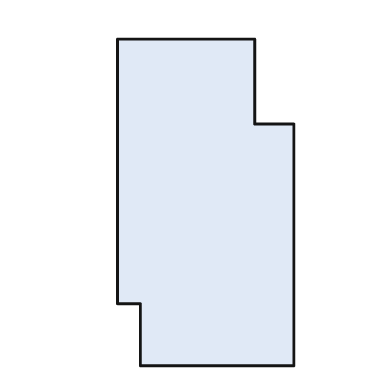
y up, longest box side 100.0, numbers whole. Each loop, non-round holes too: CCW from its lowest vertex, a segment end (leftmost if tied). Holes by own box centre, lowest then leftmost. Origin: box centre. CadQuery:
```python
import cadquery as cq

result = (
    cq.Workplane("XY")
    .moveTo(-20.0, -50.0)
    .lineTo(27.0, -50.0)
    .lineTo(27.0, 24.0)
    .lineTo(15.0, 24.0)
    .lineTo(15.0, 50.0)
    .lineTo(-27.0, 50.0)
    .lineTo(-27.0, -31.0)
    .lineTo(-20.0, -31.0)
    .close()
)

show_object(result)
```